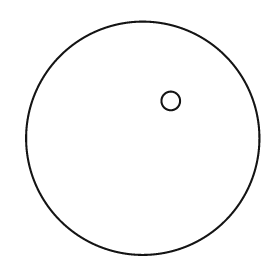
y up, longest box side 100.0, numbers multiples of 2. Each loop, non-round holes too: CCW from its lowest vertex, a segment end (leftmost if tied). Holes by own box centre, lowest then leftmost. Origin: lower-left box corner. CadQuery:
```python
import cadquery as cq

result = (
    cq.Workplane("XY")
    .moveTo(50.0, 50.0)
    .circle(50.0)
    .moveTo(62.0, 66.0)
    .circle(4.0)
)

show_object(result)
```